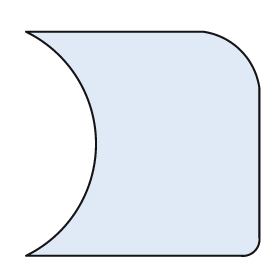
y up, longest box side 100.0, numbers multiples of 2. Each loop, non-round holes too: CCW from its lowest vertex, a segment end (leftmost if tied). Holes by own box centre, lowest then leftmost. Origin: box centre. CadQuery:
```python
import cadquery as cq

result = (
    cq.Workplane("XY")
    .moveTo(-50.0, -48.0)
    .lineTo(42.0, -48.0)
    .threePointArc((48.0, -46.0), (50.0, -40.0))
    .lineTo(50.0, 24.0)
    .threePointArc((42.0, 40.0), (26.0, 48.0))
    .lineTo(-50.0, 48.0)
    .threePointArc((-20.0, 0.0), (-50.0, -48.0))
    .close()
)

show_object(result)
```